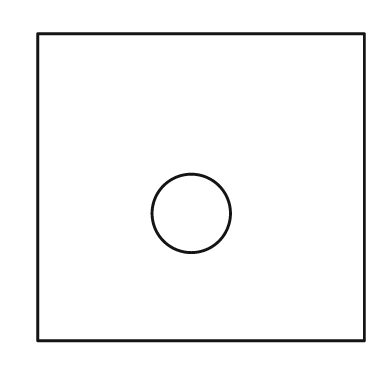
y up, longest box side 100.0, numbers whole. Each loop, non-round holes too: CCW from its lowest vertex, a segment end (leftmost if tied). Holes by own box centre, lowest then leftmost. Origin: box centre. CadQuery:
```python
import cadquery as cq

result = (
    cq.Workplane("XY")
    .moveTo(-50.0, -47.0)
    .lineTo(50.0, -47.0)
    .lineTo(50.0, 47.0)
    .lineTo(-50.0, 47.0)
    .close()
    .moveTo(-3.0, -8.0)
    .circle(12.0)
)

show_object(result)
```